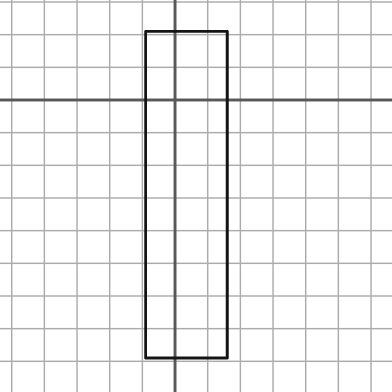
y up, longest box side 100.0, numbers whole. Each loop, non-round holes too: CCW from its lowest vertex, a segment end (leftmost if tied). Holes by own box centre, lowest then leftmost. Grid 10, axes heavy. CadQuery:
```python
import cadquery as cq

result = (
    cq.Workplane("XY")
    .moveTo(-9.0, -79.0)
    .lineTo(16.0, -79.0)
    .lineTo(16.0, 21.0)
    .lineTo(-9.0, 21.0)
    .close()
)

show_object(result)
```